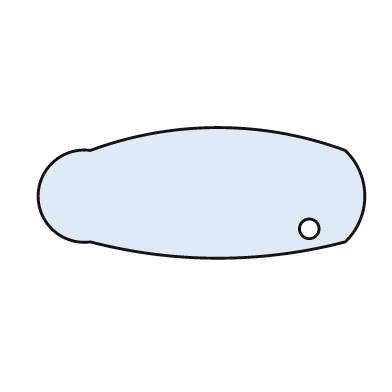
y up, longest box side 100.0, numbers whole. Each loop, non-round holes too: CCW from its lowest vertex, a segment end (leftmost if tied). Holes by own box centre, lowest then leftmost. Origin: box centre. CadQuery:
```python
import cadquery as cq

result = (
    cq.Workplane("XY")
    .moveTo(-34.0, -15.0)
    .threePointArc((5.0, -20.0), (44.0, -15.0))
    .threePointArc((50.0, -1.0), (44.0, 13.0))
    .threePointArc((5.0, 20.0), (-34.0, 13.0))
    .threePointArc((-50.0, -1.0), (-34.0, -15.0))
    .close()
    .moveTo(33.0, -11.0)
    .circle(3.0)
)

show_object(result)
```